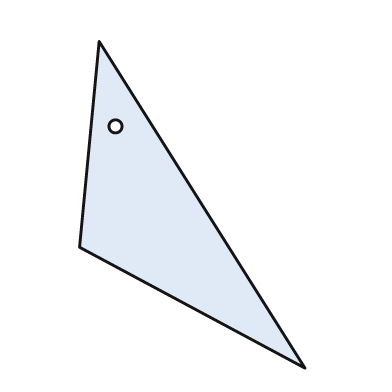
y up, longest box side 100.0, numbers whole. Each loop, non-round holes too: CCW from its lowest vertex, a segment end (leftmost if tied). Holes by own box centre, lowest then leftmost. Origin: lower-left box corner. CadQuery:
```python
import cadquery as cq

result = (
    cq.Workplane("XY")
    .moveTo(69.0, 0.0)
    .lineTo(6.0, 100.0)
    .lineTo(0.0, 37.0)
    .close()
    .moveTo(11.0, 74.0)
    .circle(2.0)
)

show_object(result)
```